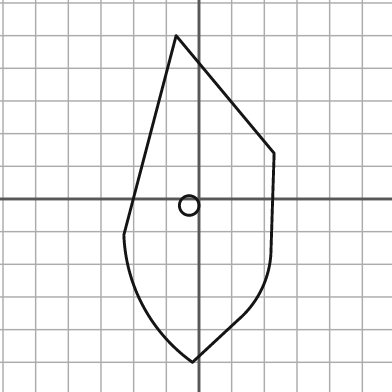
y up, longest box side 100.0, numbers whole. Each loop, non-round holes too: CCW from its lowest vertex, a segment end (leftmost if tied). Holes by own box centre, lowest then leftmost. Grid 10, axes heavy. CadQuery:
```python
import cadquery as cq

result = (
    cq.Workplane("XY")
    .moveTo(-2.0, -50.0)
    .lineTo(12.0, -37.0)
    .threePointArc((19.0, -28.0), (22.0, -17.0))
    .lineTo(23.0, 14.0)
    .lineTo(-7.0, 50.0)
    .lineTo(-23.0, -11.0)
    .threePointArc((-17.0, -33.0), (-2.0, -50.0))
    .close()
    .moveTo(-3.0, -2.0)
    .circle(3.0)
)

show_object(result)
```